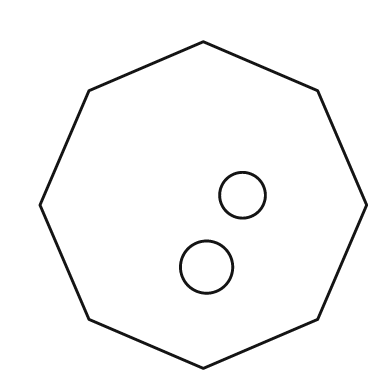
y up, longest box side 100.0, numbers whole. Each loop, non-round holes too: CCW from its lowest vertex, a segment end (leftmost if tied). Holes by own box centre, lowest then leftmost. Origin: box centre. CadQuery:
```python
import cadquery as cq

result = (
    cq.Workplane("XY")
    .moveTo(0.0, -50.0)
    .lineTo(35.0, -35.0)
    .lineTo(50.0, 0.0)
    .lineTo(35.0, 35.0)
    .lineTo(0.0, 50.0)
    .lineTo(-35.0, 35.0)
    .lineTo(-50.0, 0.0)
    .lineTo(-35.0, -35.0)
    .close()
    .moveTo(1.0, -19.0)
    .circle(8.0)
    .moveTo(12.0, 3.0)
    .circle(7.0)
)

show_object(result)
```